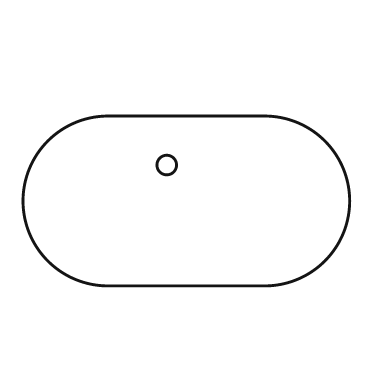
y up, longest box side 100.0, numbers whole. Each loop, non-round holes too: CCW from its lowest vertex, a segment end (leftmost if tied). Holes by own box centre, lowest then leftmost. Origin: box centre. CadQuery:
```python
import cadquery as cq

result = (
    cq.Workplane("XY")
    .moveTo(-24.0, -26.0)
    .lineTo(24.0, -26.0)
    .threePointArc((50.0, 0.0), (24.0, 26.0))
    .lineTo(-24.0, 26.0)
    .threePointArc((-50.0, 0.0), (-24.0, -26.0))
    .close()
    .moveTo(-6.0, 11.0)
    .circle(3.0)
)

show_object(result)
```